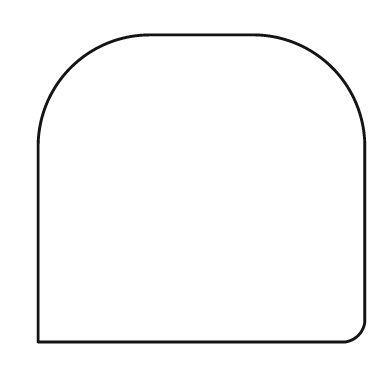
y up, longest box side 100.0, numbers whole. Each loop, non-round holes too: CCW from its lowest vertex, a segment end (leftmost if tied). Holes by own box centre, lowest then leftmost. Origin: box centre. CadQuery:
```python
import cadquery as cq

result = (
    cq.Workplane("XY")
    .moveTo(-50.0, -47.0)
    .lineTo(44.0, -47.0)
    .threePointArc((48.0, -45.0), (50.0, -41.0))
    .lineTo(50.0, 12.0)
    .threePointArc((40.0, 37.0), (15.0, 47.0))
    .lineTo(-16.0, 47.0)
    .threePointArc((-40.0, 37.0), (-50.0, 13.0))
    .close()
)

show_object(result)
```